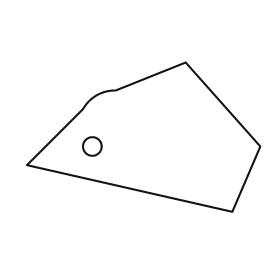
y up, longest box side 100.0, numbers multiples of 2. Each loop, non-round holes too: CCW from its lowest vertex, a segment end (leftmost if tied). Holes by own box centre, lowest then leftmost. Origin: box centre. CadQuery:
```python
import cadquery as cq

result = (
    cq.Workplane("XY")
    .moveTo(38.0, -32.0)
    .lineTo(50.0, -4.0)
    .lineTo(18.0, 32.0)
    .lineTo(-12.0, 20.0)
    .threePointArc((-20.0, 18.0), (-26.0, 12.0))
    .lineTo(-50.0, -12.0)
    .close()
    .moveTo(-22.0, -4.0)
    .circle(4.0)
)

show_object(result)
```